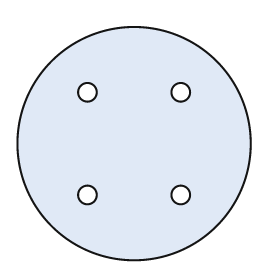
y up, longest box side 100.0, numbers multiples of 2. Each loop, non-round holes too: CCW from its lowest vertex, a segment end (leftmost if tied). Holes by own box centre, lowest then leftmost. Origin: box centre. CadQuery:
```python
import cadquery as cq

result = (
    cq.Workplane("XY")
    .moveTo(0.0, 0.0)
    .circle(50.0)
    .moveTo(-20.0, -22.0)
    .circle(4.0)
    .moveTo(20.0, -22.0)
    .circle(4.0)
    .moveTo(-20.0, 22.0)
    .circle(4.0)
    .moveTo(20.0, 22.0)
    .circle(4.0)
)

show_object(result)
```